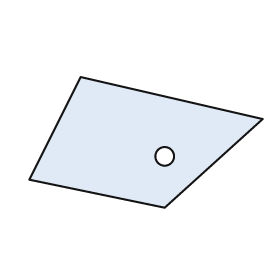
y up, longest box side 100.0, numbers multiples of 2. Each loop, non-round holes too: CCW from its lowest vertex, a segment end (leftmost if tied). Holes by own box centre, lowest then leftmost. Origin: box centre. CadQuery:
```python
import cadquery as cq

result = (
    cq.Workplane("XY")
    .moveTo(8.0, -28.0)
    .lineTo(50.0, 10.0)
    .lineTo(-28.0, 28.0)
    .lineTo(-50.0, -16.0)
    .close()
    .moveTo(8.0, -6.0)
    .circle(4.0)
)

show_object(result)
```